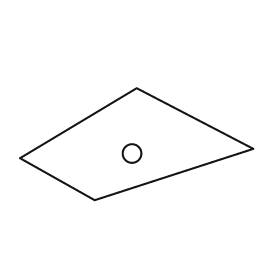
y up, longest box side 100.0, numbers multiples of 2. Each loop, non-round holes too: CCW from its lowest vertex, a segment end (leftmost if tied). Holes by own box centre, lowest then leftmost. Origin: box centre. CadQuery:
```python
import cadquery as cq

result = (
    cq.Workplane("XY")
    .moveTo(-18.0, -24.0)
    .lineTo(50.0, -2.0)
    .lineTo(0.0, 24.0)
    .lineTo(-50.0, -6.0)
    .close()
    .moveTo(-2.0, -4.0)
    .circle(4.0)
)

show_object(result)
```